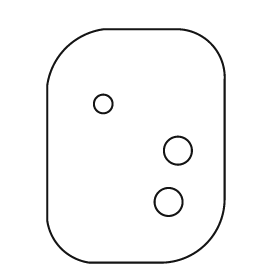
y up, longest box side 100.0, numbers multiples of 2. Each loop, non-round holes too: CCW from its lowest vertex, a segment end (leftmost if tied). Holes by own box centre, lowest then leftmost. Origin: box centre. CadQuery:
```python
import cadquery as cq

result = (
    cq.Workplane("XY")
    .moveTo(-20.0, -50.0)
    .lineTo(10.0, -50.0)
    .threePointArc((30.0, -42.0), (38.0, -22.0))
    .lineTo(38.0, 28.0)
    .threePointArc((32.0, 44.0), (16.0, 50.0))
    .lineTo(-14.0, 50.0)
    .threePointArc((-30.0, 42.0), (-38.0, 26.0))
    .lineTo(-38.0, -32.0)
    .threePointArc((-32.0, -44.0), (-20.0, -50.0))
    .close()
    .moveTo(14.0, -24.0)
    .circle(6.0)
    .moveTo(18.0, -2.0)
    .circle(6.0)
    .moveTo(-14.0, 18.0)
    .circle(4.0)
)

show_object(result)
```